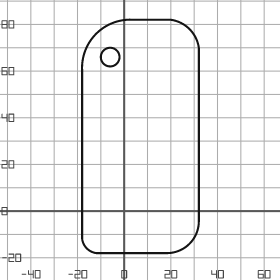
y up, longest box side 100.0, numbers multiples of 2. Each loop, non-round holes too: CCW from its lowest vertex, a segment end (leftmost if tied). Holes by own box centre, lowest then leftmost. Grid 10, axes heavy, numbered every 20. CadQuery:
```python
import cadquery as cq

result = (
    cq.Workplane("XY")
    .moveTo(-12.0, -18.0)
    .lineTo(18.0, -18.0)
    .threePointArc((28.0, -14.0), (32.0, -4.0))
    .lineTo(32.0, 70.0)
    .threePointArc((28.0, 78.0), (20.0, 82.0))
    .lineTo(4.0, 82.0)
    .threePointArc((-12.0, 76.0), (-18.0, 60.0))
    .lineTo(-18.0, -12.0)
    .threePointArc((-16.0, -16.0), (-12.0, -18.0))
    .close()
    .moveTo(-6.0, 66.0)
    .circle(4.0)
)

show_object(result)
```